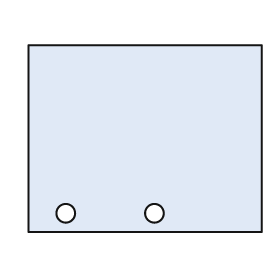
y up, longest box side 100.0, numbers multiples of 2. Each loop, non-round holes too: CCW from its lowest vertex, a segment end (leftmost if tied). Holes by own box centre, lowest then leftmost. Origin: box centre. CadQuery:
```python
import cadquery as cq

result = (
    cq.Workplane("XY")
    .moveTo(-50.0, -40.0)
    .lineTo(50.0, -40.0)
    .lineTo(50.0, 40.0)
    .lineTo(-50.0, 40.0)
    .close()
    .moveTo(-34.0, -32.0)
    .circle(4.0)
    .moveTo(4.0, -32.0)
    .circle(4.0)
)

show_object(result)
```